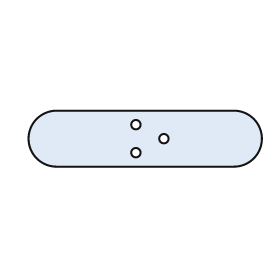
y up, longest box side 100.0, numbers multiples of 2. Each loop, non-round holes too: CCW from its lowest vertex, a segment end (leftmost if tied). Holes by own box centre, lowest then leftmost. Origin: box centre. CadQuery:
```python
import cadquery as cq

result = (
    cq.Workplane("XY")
    .moveTo(-38.0, -12.0)
    .lineTo(38.0, -12.0)
    .threePointArc((50.0, 0.0), (38.0, 12.0))
    .lineTo(-38.0, 12.0)
    .threePointArc((-50.0, 0.0), (-38.0, -12.0))
    .close()
    .moveTo(-4.0, -6.0)
    .circle(2.0)
    .moveTo(8.0, 0.0)
    .circle(2.0)
    .moveTo(-4.0, 6.0)
    .circle(2.0)
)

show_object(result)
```